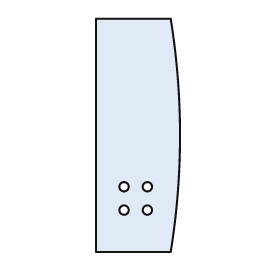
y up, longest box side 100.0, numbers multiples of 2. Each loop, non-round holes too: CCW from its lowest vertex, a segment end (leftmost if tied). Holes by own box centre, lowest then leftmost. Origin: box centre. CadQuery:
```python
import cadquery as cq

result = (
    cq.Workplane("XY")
    .moveTo(-18.0, -50.0)
    .lineTo(14.0, -50.0)
    .threePointArc((18.0, 0.0), (14.0, 50.0))
    .lineTo(-18.0, 50.0)
    .close()
    .moveTo(-6.0, -32.0)
    .circle(2.0)
    .moveTo(4.0, -32.0)
    .circle(2.0)
    .moveTo(-6.0, -22.0)
    .circle(2.0)
    .moveTo(4.0, -22.0)
    .circle(2.0)
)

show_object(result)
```